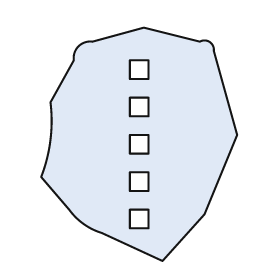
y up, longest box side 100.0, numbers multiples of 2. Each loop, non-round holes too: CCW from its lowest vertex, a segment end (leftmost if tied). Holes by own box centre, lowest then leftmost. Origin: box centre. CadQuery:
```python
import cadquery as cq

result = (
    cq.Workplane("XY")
    .moveTo(10.0, -50.0)
    .lineTo(28.0, -30.0)
    .lineTo(42.0, 4.0)
    .lineTo(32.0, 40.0)
    .threePointArc((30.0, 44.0), (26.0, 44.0))
    .lineTo(2.0, 50.0)
    .lineTo(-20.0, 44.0)
    .threePointArc((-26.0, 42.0), (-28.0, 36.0))
    .lineTo(-38.0, 18.0)
    .threePointArc((-38.0, 2.0), (-42.0, -14.0))
    .lineTo(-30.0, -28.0)
    .threePointArc((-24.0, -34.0), (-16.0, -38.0))
    .close()
    .moveTo(-4.0, -36.0)
    .lineTo(4.0, -36.0)
    .lineTo(4.0, -28.0)
    .lineTo(-4.0, -28.0)
    .close()
    .moveTo(-4.0, -20.0)
    .lineTo(4.0, -20.0)
    .lineTo(4.0, -12.0)
    .lineTo(-4.0, -12.0)
    .close()
    .moveTo(-4.0, -4.0)
    .lineTo(4.0, -4.0)
    .lineTo(4.0, 4.0)
    .lineTo(-4.0, 4.0)
    .close()
    .moveTo(-4.0, 12.0)
    .lineTo(4.0, 12.0)
    .lineTo(4.0, 20.0)
    .lineTo(-4.0, 20.0)
    .close()
    .moveTo(-4.0, 28.0)
    .lineTo(4.0, 28.0)
    .lineTo(4.0, 36.0)
    .lineTo(-4.0, 36.0)
    .close()
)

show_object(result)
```